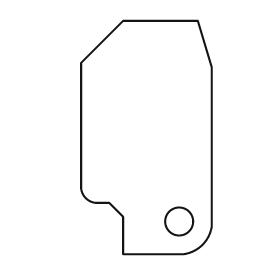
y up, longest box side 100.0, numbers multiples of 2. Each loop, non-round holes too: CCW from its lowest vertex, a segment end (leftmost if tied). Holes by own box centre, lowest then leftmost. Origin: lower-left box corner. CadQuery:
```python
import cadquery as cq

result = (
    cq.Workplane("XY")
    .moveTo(18.0, 0.0)
    .lineTo(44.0, 0.0)
    .threePointArc((52.0, 4.0), (56.0, 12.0))
    .lineTo(56.0, 80.0)
    .lineTo(50.0, 100.0)
    .lineTo(18.0, 100.0)
    .lineTo(0.0, 82.0)
    .lineTo(0.0, 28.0)
    .threePointArc((2.0, 24.0), (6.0, 22.0))
    .lineTo(12.0, 22.0)
    .lineTo(18.0, 16.0)
    .close()
    .moveTo(42.0, 14.0)
    .circle(6.0)
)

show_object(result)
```